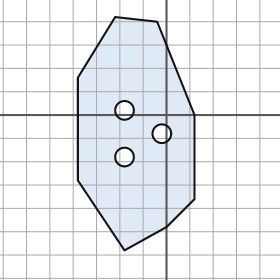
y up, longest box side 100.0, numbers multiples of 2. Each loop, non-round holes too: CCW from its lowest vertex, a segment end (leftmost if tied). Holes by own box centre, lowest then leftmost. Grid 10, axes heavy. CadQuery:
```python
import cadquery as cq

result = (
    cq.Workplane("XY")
    .moveTo(-18.0, -58.0)
    .lineTo(0.0, -48.0)
    .lineTo(12.0, -36.0)
    .lineTo(12.0, 0.0)
    .lineTo(-4.0, 40.0)
    .lineTo(-22.0, 42.0)
    .lineTo(-38.0, 16.0)
    .lineTo(-38.0, -28.0)
    .close()
    .moveTo(-18.0, -18.0)
    .circle(4.0)
    .moveTo(-2.0, -8.0)
    .circle(4.0)
    .moveTo(-18.0, 2.0)
    .circle(4.0)
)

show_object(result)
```